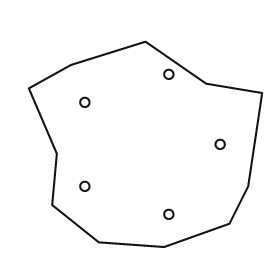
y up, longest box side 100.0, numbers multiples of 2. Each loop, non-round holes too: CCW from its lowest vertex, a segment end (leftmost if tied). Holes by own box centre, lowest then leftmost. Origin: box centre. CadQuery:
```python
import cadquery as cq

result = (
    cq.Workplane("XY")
    .moveTo(8.0, -44.0)
    .lineTo(36.0, -34.0)
    .lineTo(44.0, -18.0)
    .lineTo(50.0, 22.0)
    .lineTo(26.0, 26.0)
    .lineTo(0.0, 44.0)
    .lineTo(-32.0, 34.0)
    .lineTo(-50.0, 24.0)
    .lineTo(-38.0, -4.0)
    .lineTo(-40.0, -26.0)
    .lineTo(-20.0, -42.0)
    .close()
    .moveTo(10.0, -30.0)
    .circle(2.0)
    .moveTo(-26.0, -18.0)
    .circle(2.0)
    .moveTo(32.0, 0.0)
    .circle(2.0)
    .moveTo(-26.0, 18.0)
    .circle(2.0)
    .moveTo(10.0, 30.0)
    .circle(2.0)
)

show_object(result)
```